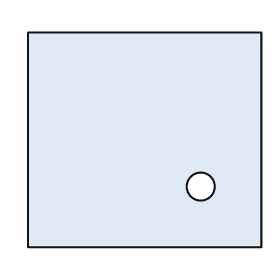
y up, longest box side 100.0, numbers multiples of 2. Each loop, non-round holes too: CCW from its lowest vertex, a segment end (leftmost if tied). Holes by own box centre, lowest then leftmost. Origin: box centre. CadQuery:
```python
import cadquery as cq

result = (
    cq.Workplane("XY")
    .moveTo(-50.0, -46.0)
    .lineTo(50.0, -46.0)
    .lineTo(50.0, 46.0)
    .lineTo(-50.0, 46.0)
    .close()
    .moveTo(24.0, -20.0)
    .circle(6.0)
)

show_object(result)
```